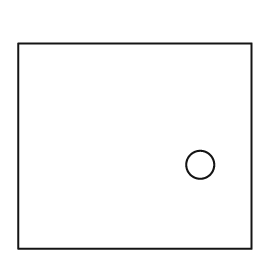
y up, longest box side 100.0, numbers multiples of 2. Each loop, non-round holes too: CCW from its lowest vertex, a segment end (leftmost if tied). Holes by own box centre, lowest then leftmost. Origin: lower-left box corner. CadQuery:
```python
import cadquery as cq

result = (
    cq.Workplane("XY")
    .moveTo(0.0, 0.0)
    .lineTo(100.0, 0.0)
    .lineTo(100.0, 88.0)
    .lineTo(0.0, 88.0)
    .close()
    .moveTo(78.0, 36.0)
    .circle(6.0)
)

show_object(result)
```